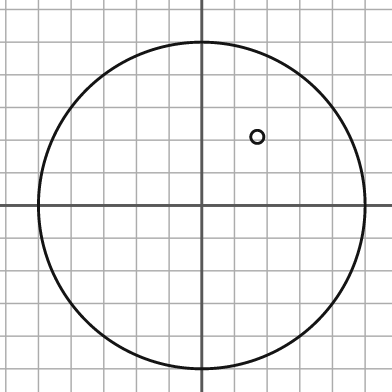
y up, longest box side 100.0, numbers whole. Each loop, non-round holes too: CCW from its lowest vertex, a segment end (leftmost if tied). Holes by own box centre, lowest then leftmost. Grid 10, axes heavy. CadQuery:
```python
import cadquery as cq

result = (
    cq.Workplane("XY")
    .moveTo(0.0, 0.0)
    .circle(50.0)
    .moveTo(17.0, 21.0)
    .circle(2.0)
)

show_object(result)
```